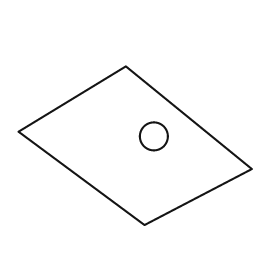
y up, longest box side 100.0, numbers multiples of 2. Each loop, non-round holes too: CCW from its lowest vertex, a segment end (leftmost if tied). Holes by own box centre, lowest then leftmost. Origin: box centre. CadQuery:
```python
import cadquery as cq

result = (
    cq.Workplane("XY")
    .moveTo(4.0, -34.0)
    .lineTo(50.0, -10.0)
    .lineTo(-4.0, 34.0)
    .lineTo(-50.0, 6.0)
    .close()
    .moveTo(8.0, 4.0)
    .circle(6.0)
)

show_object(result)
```